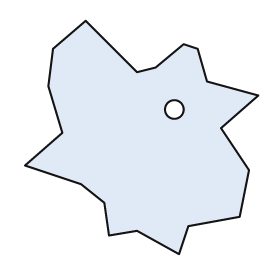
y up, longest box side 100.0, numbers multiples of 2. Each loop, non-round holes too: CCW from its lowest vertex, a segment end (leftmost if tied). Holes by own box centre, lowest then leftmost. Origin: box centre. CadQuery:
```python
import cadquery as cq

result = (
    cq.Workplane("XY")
    .moveTo(16.0, -50.0)
    .lineTo(20.0, -38.0)
    .lineTo(42.0, -34.0)
    .lineTo(46.0, -14.0)
    .lineTo(34.0, 4.0)
    .lineTo(50.0, 18.0)
    .lineTo(28.0, 24.0)
    .lineTo(24.0, 38.0)
    .lineTo(18.0, 40.0)
    .lineTo(6.0, 30.0)
    .lineTo(-2.0, 28.0)
    .lineTo(-24.0, 50.0)
    .lineTo(-38.0, 38.0)
    .lineTo(-40.0, 22.0)
    .lineTo(-34.0, 2.0)
    .lineTo(-50.0, -12.0)
    .lineTo(-26.0, -20.0)
    .lineTo(-16.0, -28.0)
    .lineTo(-14.0, -42.0)
    .lineTo(-2.0, -40.0)
    .close()
    .moveTo(14.0, 12.0)
    .circle(4.0)
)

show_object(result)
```